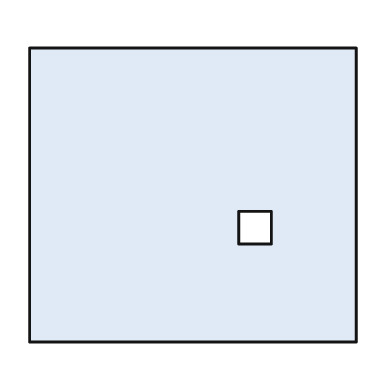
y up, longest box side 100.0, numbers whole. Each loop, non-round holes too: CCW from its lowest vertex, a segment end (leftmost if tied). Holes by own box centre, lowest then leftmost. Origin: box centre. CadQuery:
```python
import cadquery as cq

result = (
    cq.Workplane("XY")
    .moveTo(-50.0, -45.0)
    .lineTo(50.0, -45.0)
    .lineTo(50.0, 45.0)
    .lineTo(-50.0, 45.0)
    .close()
    .moveTo(14.0, -15.0)
    .lineTo(24.0, -15.0)
    .lineTo(24.0, -5.0)
    .lineTo(14.0, -5.0)
    .close()
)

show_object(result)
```